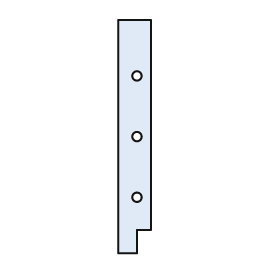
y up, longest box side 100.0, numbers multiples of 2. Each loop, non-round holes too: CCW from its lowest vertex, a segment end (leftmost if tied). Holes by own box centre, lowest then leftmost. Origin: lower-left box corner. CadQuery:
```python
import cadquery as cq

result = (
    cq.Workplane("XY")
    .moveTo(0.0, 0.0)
    .lineTo(8.0, 0.0)
    .lineTo(8.0, 10.0)
    .lineTo(14.0, 10.0)
    .lineTo(14.0, 100.0)
    .lineTo(0.0, 100.0)
    .close()
    .moveTo(8.0, 24.0)
    .circle(2.0)
    .moveTo(8.0, 50.0)
    .circle(2.0)
    .moveTo(8.0, 76.0)
    .circle(2.0)
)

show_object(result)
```